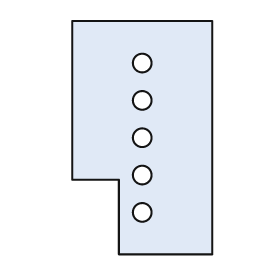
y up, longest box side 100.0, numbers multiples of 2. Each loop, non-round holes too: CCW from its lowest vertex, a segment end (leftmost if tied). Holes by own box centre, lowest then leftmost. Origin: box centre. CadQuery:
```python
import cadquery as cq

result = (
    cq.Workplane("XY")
    .moveTo(-10.0, -50.0)
    .lineTo(30.0, -50.0)
    .lineTo(30.0, 50.0)
    .lineTo(-30.0, 50.0)
    .lineTo(-30.0, -18.0)
    .lineTo(-10.0, -18.0)
    .close()
    .moveTo(0.0, -32.0)
    .circle(4.0)
    .moveTo(0.0, -16.0)
    .circle(4.0)
    .moveTo(0.0, 0.0)
    .circle(4.0)
    .moveTo(0.0, 16.0)
    .circle(4.0)
    .moveTo(0.0, 32.0)
    .circle(4.0)
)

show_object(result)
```